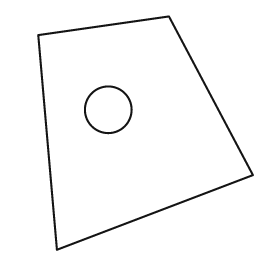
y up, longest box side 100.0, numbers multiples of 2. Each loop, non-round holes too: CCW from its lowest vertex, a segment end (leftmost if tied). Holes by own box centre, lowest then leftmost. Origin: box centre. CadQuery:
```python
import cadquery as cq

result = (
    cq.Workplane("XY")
    .moveTo(-38.0, -50.0)
    .lineTo(46.0, -18.0)
    .lineTo(10.0, 50.0)
    .lineTo(-46.0, 42.0)
    .close()
    .moveTo(-16.0, 10.0)
    .circle(10.0)
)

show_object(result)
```